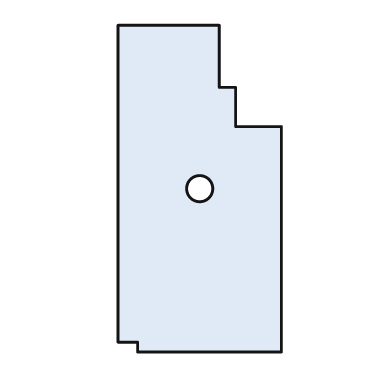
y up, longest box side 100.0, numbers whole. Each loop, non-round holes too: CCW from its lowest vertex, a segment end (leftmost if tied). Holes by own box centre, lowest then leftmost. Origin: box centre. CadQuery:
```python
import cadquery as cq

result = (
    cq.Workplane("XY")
    .moveTo(-19.0, -50.0)
    .lineTo(25.0, -50.0)
    .lineTo(25.0, 19.0)
    .lineTo(11.0, 19.0)
    .lineTo(11.0, 31.0)
    .lineTo(6.0, 31.0)
    .lineTo(6.0, 50.0)
    .lineTo(-25.0, 50.0)
    .lineTo(-25.0, -47.0)
    .lineTo(-19.0, -47.0)
    .close()
    .moveTo(0.0, 0.0)
    .circle(4.0)
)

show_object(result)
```